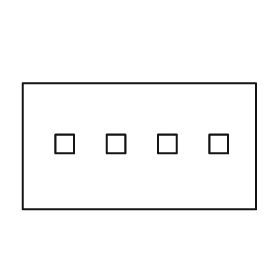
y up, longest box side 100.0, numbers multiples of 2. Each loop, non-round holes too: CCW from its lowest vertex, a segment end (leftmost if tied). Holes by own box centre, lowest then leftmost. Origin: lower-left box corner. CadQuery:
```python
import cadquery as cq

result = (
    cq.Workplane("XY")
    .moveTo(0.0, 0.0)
    .lineTo(100.0, 0.0)
    .lineTo(100.0, 54.0)
    .lineTo(0.0, 54.0)
    .close()
    .moveTo(14.0, 24.0)
    .lineTo(22.0, 24.0)
    .lineTo(22.0, 32.0)
    .lineTo(14.0, 32.0)
    .close()
    .moveTo(36.0, 24.0)
    .lineTo(44.0, 24.0)
    .lineTo(44.0, 32.0)
    .lineTo(36.0, 32.0)
    .close()
    .moveTo(58.0, 24.0)
    .lineTo(66.0, 24.0)
    .lineTo(66.0, 32.0)
    .lineTo(58.0, 32.0)
    .close()
    .moveTo(80.0, 24.0)
    .lineTo(88.0, 24.0)
    .lineTo(88.0, 32.0)
    .lineTo(80.0, 32.0)
    .close()
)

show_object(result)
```